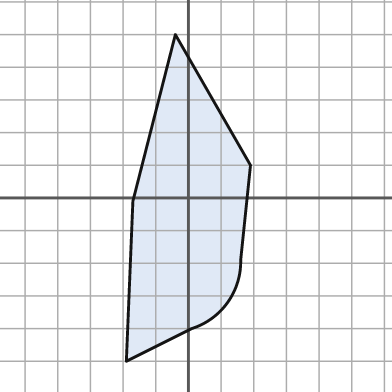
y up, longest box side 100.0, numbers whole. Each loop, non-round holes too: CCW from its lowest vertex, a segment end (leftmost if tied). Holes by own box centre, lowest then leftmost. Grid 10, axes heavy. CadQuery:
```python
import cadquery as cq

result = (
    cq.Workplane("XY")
    .moveTo(-19.0, -50.0)
    .lineTo(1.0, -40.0)
    .threePointArc((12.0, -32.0), (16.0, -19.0))
    .lineTo(19.0, 10.0)
    .lineTo(-4.0, 50.0)
    .lineTo(-17.0, -1.0)
    .close()
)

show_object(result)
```